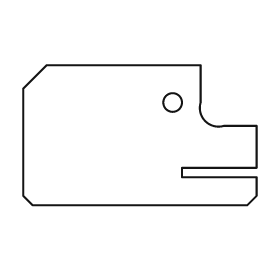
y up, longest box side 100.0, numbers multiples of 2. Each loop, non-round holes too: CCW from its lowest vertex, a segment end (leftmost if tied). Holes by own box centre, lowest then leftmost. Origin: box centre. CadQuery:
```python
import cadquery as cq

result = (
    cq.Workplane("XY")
    .moveTo(-46.0, -30.0)
    .lineTo(46.0, -30.0)
    .lineTo(50.0, -26.0)
    .lineTo(50.0, -18.0)
    .lineTo(18.0, -18.0)
    .lineTo(18.0, -14.0)
    .lineTo(50.0, -14.0)
    .lineTo(50.0, 4.0)
    .lineTo(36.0, 4.0)
    .threePointArc((28.0, 6.0), (26.0, 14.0))
    .lineTo(26.0, 30.0)
    .lineTo(-40.0, 30.0)
    .lineTo(-50.0, 20.0)
    .lineTo(-50.0, -26.0)
    .close()
    .moveTo(14.0, 14.0)
    .circle(4.0)
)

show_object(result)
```